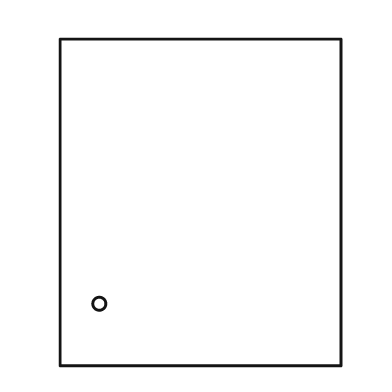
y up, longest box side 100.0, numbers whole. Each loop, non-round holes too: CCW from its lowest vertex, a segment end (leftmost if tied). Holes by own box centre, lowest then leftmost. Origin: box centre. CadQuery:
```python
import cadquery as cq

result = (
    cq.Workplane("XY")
    .moveTo(-43.0, -50.0)
    .lineTo(43.0, -50.0)
    .lineTo(43.0, 50.0)
    .lineTo(-43.0, 50.0)
    .close()
    .moveTo(-31.0, -31.0)
    .circle(2.0)
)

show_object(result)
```